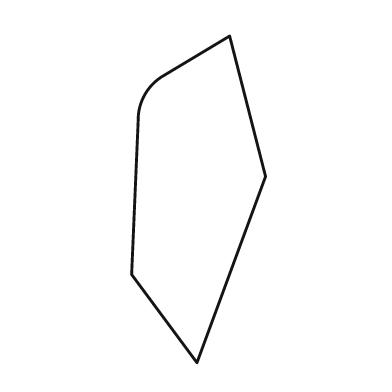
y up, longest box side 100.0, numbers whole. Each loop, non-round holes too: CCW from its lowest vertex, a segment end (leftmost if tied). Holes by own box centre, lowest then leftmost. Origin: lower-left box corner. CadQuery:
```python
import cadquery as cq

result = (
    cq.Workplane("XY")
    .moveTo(20.0, 0.0)
    .lineTo(41.0, 57.0)
    .lineTo(30.0, 100.0)
    .lineTo(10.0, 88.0)
    .threePointArc((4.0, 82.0), (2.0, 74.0))
    .lineTo(0.0, 27.0)
    .close()
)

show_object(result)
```